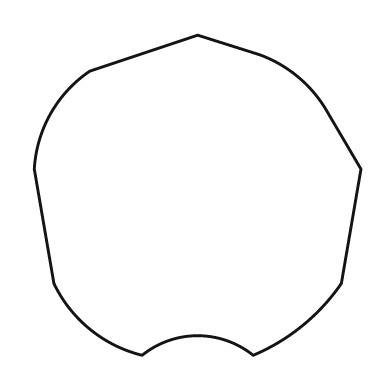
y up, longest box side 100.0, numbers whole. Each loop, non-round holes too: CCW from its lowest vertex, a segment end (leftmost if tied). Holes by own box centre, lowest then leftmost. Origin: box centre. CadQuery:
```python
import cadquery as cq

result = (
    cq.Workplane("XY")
    .moveTo(-17.0, -49.0)
    .threePointArc((0.0, -43.0), (17.0, -49.0))
    .threePointArc((32.0, -40.0), (44.0, -27.0))
    .lineTo(50.0, 8.0)
    .lineTo(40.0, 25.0)
    .threePointArc((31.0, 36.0), (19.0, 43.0))
    .lineTo(0.0, 49.0)
    .lineTo(-33.0, 38.0)
    .threePointArc((-45.0, 25.0), (-50.0, 8.0))
    .lineTo(-44.0, -27.0)
    .threePointArc((-33.0, -41.0), (-17.0, -49.0))
    .close()
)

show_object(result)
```